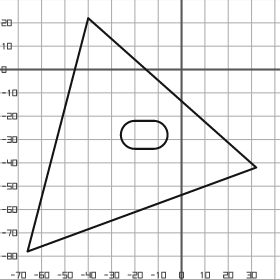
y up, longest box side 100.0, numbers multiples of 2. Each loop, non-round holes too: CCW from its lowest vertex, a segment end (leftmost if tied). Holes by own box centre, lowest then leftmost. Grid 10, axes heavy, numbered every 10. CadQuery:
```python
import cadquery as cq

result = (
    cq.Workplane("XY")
    .moveTo(-66.0, -78.0)
    .lineTo(32.0, -42.0)
    .lineTo(-40.0, 22.0)
    .close()
    .moveTo(-20.0, -34.0)
    .lineTo(-12.0, -34.0)
    .threePointArc((-6.0, -28.0), (-12.0, -22.0))
    .lineTo(-20.0, -22.0)
    .threePointArc((-26.0, -28.0), (-20.0, -34.0))
    .close()
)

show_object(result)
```